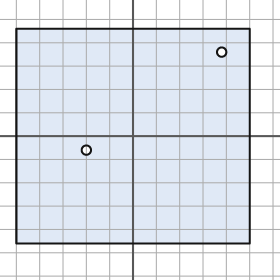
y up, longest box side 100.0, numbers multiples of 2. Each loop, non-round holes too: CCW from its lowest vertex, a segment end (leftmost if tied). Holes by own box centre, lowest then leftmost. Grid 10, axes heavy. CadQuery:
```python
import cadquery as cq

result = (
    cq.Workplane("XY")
    .moveTo(-50.0, -46.0)
    .lineTo(50.0, -46.0)
    .lineTo(50.0, 46.0)
    .lineTo(-50.0, 46.0)
    .close()
    .moveTo(-20.0, -6.0)
    .circle(2.0)
    .moveTo(38.0, 36.0)
    .circle(2.0)
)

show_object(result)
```